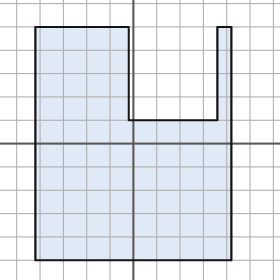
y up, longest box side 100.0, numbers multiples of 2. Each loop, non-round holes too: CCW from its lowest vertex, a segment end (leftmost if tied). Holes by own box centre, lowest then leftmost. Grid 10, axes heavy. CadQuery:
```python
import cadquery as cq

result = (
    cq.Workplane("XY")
    .moveTo(-42.0, -50.0)
    .lineTo(42.0, -50.0)
    .lineTo(42.0, 50.0)
    .lineTo(36.0, 50.0)
    .lineTo(36.0, 10.0)
    .lineTo(-2.0, 10.0)
    .lineTo(-2.0, 50.0)
    .lineTo(-42.0, 50.0)
    .close()
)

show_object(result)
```